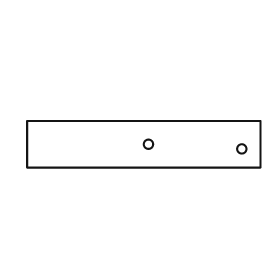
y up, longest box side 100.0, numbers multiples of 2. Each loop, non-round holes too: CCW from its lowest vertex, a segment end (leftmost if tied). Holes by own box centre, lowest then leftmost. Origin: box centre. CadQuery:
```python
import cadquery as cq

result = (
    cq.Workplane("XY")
    .moveTo(-50.0, -10.0)
    .lineTo(50.0, -10.0)
    .lineTo(50.0, 10.0)
    .lineTo(-50.0, 10.0)
    .close()
    .moveTo(42.0, -2.0)
    .circle(2.0)
    .moveTo(2.0, 0.0)
    .circle(2.0)
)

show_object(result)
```